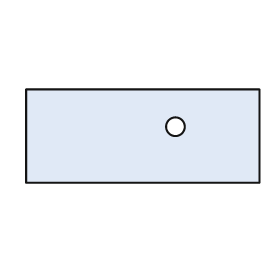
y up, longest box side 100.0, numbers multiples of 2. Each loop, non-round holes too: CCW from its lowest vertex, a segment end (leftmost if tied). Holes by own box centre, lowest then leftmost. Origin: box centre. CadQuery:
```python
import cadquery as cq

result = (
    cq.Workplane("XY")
    .moveTo(-50.0, -20.0)
    .lineTo(50.0, -20.0)
    .lineTo(50.0, 20.0)
    .lineTo(-50.0, 20.0)
    .close()
    .moveTo(14.0, 4.0)
    .circle(4.0)
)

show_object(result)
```